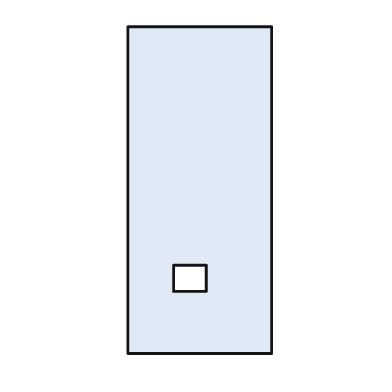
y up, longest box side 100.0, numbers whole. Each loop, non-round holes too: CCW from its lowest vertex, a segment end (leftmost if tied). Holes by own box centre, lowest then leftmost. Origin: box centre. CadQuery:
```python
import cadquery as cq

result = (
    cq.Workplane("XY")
    .moveTo(-22.0, -50.0)
    .lineTo(22.0, -50.0)
    .lineTo(22.0, 50.0)
    .lineTo(-22.0, 50.0)
    .close()
    .moveTo(-8.0, -31.0)
    .lineTo(2.0, -31.0)
    .lineTo(2.0, -23.0)
    .lineTo(-8.0, -23.0)
    .close()
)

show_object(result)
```